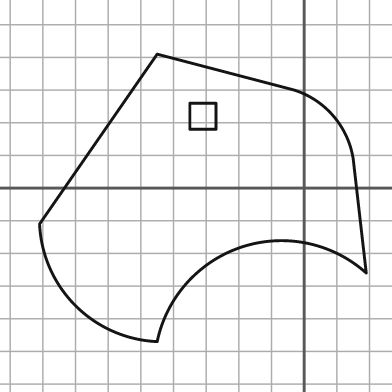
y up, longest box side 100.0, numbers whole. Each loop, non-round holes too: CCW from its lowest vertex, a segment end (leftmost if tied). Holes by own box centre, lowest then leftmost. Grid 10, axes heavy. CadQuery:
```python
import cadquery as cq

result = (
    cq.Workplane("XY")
    .moveTo(-45.0, -47.0)
    .threePointArc((-19.0, -18.0), (19.0, -26.0))
    .lineTo(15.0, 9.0)
    .threePointArc((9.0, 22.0), (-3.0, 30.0))
    .lineTo(-45.0, 41.0)
    .lineTo(-81.0, -11.0)
    .threePointArc((-70.0, -36.0), (-45.0, -47.0))
    .close()
    .moveTo(-35.0, 18.0)
    .lineTo(-27.0, 18.0)
    .lineTo(-27.0, 26.0)
    .lineTo(-35.0, 26.0)
    .close()
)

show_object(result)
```